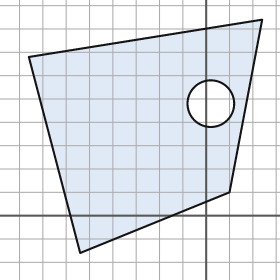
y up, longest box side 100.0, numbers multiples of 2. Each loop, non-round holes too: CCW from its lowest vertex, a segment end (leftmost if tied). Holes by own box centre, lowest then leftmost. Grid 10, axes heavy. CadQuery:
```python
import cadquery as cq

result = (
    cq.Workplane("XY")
    .moveTo(-54.0, -16.0)
    .lineTo(10.0, 10.0)
    .lineTo(24.0, 84.0)
    .lineTo(-76.0, 68.0)
    .close()
    .moveTo(2.0, 48.0)
    .circle(10.0)
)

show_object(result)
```